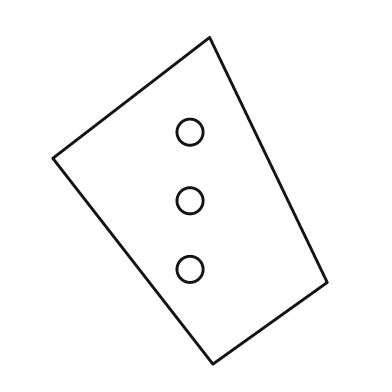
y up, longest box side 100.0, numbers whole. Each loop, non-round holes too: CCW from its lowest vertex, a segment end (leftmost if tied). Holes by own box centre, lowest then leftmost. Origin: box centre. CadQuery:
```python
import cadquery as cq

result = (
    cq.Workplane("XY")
    .moveTo(7.0, -50.0)
    .lineTo(42.0, -25.0)
    .lineTo(6.0, 50.0)
    .lineTo(-42.0, 13.0)
    .close()
    .moveTo(0.0, -21.0)
    .circle(4.0)
    .moveTo(0.0, 0.0)
    .circle(4.0)
    .moveTo(0.0, 21.0)
    .circle(4.0)
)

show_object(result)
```